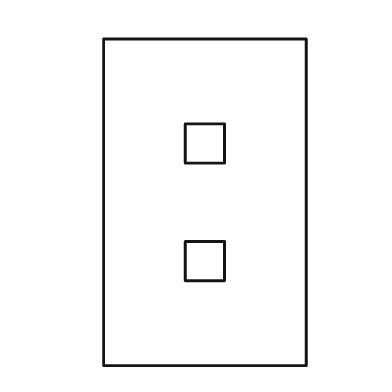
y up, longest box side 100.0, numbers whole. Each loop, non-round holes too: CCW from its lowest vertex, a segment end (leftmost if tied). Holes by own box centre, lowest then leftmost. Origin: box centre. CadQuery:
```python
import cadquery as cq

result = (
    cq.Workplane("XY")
    .moveTo(-31.0, -50.0)
    .lineTo(31.0, -50.0)
    .lineTo(31.0, 50.0)
    .lineTo(-31.0, 50.0)
    .close()
    .moveTo(-6.0, -24.0)
    .lineTo(6.0, -24.0)
    .lineTo(6.0, -12.0)
    .lineTo(-6.0, -12.0)
    .close()
    .moveTo(-6.0, 12.0)
    .lineTo(6.0, 12.0)
    .lineTo(6.0, 24.0)
    .lineTo(-6.0, 24.0)
    .close()
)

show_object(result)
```